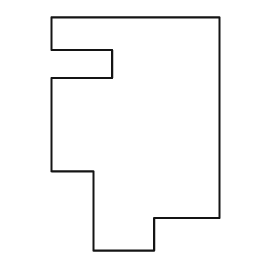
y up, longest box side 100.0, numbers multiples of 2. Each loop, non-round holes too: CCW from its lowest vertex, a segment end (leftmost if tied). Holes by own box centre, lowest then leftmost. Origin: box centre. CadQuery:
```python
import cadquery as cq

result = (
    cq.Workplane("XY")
    .moveTo(-18.0, -50.0)
    .lineTo(8.0, -50.0)
    .lineTo(8.0, -36.0)
    .lineTo(36.0, -36.0)
    .lineTo(36.0, 50.0)
    .lineTo(-36.0, 50.0)
    .lineTo(-36.0, 36.0)
    .lineTo(-10.0, 36.0)
    .lineTo(-10.0, 24.0)
    .lineTo(-36.0, 24.0)
    .lineTo(-36.0, -16.0)
    .lineTo(-18.0, -16.0)
    .close()
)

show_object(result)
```